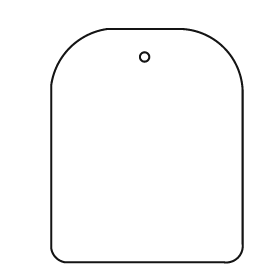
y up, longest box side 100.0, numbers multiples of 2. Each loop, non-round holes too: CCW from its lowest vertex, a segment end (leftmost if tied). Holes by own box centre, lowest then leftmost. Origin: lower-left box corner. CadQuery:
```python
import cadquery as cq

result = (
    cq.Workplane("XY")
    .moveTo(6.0, 0.0)
    .lineTo(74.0, 0.0)
    .threePointArc((80.0, 2.0), (82.0, 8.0))
    .lineTo(82.0, 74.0)
    .threePointArc((74.0, 92.0), (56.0, 100.0))
    .lineTo(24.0, 100.0)
    .threePointArc((8.0, 92.0), (0.0, 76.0))
    .lineTo(0.0, 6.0)
    .threePointArc((2.0, 2.0), (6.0, 0.0))
    .close()
    .moveTo(40.0, 88.0)
    .circle(2.0)
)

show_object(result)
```